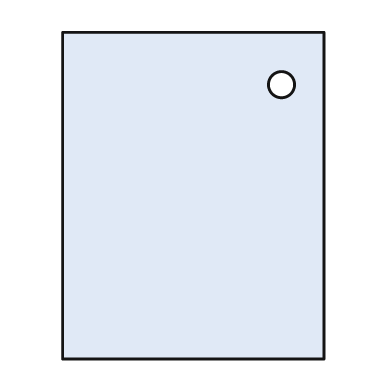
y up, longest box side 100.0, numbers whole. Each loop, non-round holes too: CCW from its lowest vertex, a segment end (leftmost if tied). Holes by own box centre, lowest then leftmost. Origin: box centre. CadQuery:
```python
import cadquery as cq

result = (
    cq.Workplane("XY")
    .moveTo(-40.0, -50.0)
    .lineTo(40.0, -50.0)
    .lineTo(40.0, 50.0)
    .lineTo(-40.0, 50.0)
    .close()
    .moveTo(27.0, 34.0)
    .circle(4.0)
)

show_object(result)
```